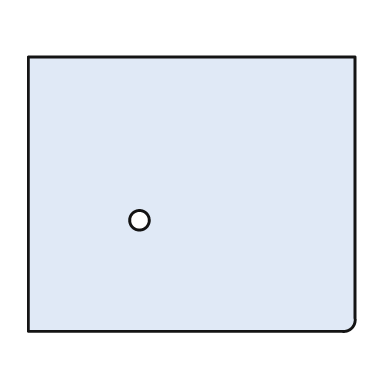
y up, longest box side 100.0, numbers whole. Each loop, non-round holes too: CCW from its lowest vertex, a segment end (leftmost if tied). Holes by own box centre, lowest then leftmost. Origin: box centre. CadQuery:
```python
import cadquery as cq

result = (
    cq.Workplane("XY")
    .moveTo(-50.0, -42.0)
    .lineTo(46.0, -42.0)
    .threePointArc((49.0, -41.0), (50.0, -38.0))
    .lineTo(50.0, 42.0)
    .lineTo(-50.0, 42.0)
    .close()
    .moveTo(-16.0, -8.0)
    .circle(3.0)
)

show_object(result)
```